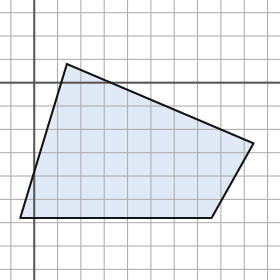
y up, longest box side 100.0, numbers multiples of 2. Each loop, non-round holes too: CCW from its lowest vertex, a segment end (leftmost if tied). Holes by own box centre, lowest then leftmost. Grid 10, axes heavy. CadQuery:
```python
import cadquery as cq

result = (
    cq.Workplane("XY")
    .moveTo(-6.0, -58.0)
    .lineTo(76.0, -58.0)
    .lineTo(94.0, -26.0)
    .lineTo(14.0, 8.0)
    .close()
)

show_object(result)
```